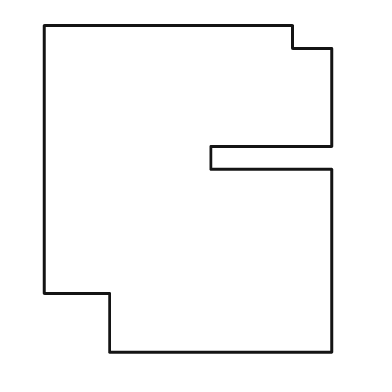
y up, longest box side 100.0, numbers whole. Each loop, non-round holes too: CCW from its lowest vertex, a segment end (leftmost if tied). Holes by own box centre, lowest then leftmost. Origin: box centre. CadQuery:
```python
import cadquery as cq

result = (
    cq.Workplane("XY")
    .moveTo(-24.0, -50.0)
    .lineTo(44.0, -50.0)
    .lineTo(44.0, 6.0)
    .lineTo(7.0, 6.0)
    .lineTo(7.0, 13.0)
    .lineTo(44.0, 13.0)
    .lineTo(44.0, 43.0)
    .lineTo(32.0, 43.0)
    .lineTo(32.0, 50.0)
    .lineTo(-44.0, 50.0)
    .lineTo(-44.0, -32.0)
    .lineTo(-24.0, -32.0)
    .close()
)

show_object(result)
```